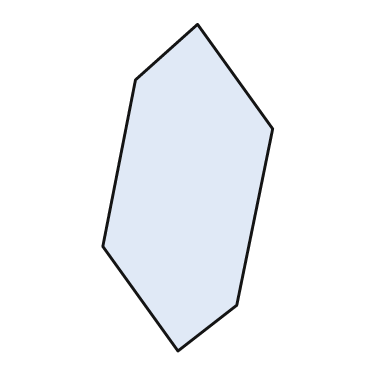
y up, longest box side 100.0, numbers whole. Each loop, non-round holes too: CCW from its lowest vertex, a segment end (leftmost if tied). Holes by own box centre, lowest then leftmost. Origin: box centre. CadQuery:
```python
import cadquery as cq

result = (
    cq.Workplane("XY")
    .moveTo(-3.0, -50.0)
    .lineTo(15.0, -36.0)
    .lineTo(26.0, 18.0)
    .lineTo(3.0, 50.0)
    .lineTo(-16.0, 33.0)
    .lineTo(-26.0, -18.0)
    .close()
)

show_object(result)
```